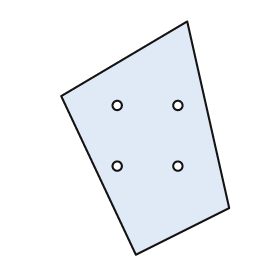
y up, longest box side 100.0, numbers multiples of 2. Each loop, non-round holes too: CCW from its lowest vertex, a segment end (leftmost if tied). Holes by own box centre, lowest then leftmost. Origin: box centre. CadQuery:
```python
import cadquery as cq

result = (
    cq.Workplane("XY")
    .moveTo(-4.0, -50.0)
    .lineTo(36.0, -30.0)
    .lineTo(18.0, 50.0)
    .lineTo(-36.0, 18.0)
    .close()
    .moveTo(-12.0, -12.0)
    .circle(2.0)
    .moveTo(14.0, -12.0)
    .circle(2.0)
    .moveTo(-12.0, 14.0)
    .circle(2.0)
    .moveTo(14.0, 14.0)
    .circle(2.0)
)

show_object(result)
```